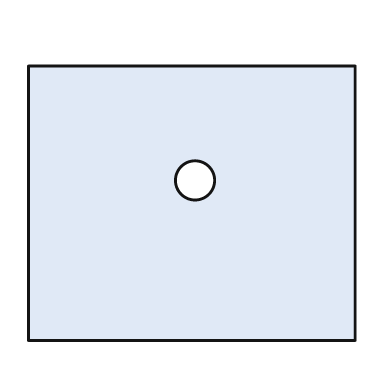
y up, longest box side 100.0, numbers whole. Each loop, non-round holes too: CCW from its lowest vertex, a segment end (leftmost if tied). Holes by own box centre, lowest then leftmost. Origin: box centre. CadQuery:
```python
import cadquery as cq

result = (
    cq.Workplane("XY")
    .moveTo(-50.0, -42.0)
    .lineTo(50.0, -42.0)
    .lineTo(50.0, 42.0)
    .lineTo(-50.0, 42.0)
    .close()
    .moveTo(1.0, 7.0)
    .circle(6.0)
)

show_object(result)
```